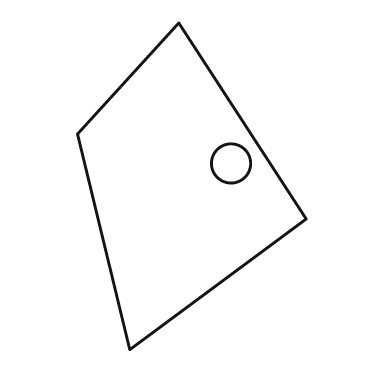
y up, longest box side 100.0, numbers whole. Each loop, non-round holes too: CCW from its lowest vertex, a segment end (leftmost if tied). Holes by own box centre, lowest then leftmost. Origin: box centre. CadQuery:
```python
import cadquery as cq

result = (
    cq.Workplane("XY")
    .moveTo(-19.0, -50.0)
    .lineTo(35.0, -10.0)
    .lineTo(-4.0, 50.0)
    .lineTo(-35.0, 16.0)
    .close()
    .moveTo(12.0, 7.0)
    .circle(6.0)
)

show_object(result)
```